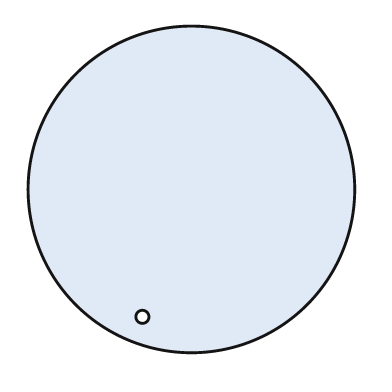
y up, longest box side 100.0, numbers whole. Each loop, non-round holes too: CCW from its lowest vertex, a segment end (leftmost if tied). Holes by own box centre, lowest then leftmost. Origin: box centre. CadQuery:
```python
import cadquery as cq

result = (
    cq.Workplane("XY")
    .moveTo(0.0, 0.0)
    .circle(50.0)
    .moveTo(-15.0, -39.0)
    .circle(2.0)
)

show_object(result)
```